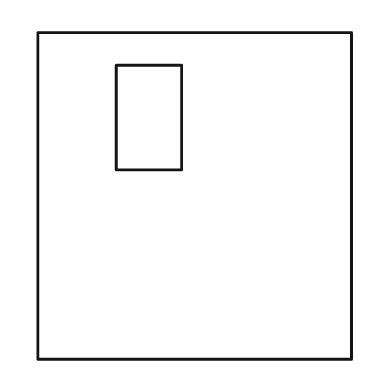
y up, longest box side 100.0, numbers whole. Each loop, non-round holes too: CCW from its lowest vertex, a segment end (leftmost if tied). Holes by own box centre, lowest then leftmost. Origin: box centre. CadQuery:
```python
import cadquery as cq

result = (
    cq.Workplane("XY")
    .moveTo(-48.0, -50.0)
    .lineTo(48.0, -50.0)
    .lineTo(48.0, 50.0)
    .lineTo(-48.0, 50.0)
    .close()
    .moveTo(-24.0, 8.0)
    .lineTo(-4.0, 8.0)
    .lineTo(-4.0, 40.0)
    .lineTo(-24.0, 40.0)
    .close()
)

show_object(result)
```